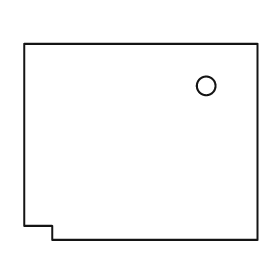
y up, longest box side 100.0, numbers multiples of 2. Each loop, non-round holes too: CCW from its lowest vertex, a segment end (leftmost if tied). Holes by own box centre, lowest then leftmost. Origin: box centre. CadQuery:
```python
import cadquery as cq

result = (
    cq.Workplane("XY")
    .moveTo(-38.0, -42.0)
    .lineTo(50.0, -42.0)
    .lineTo(50.0, 42.0)
    .lineTo(-50.0, 42.0)
    .lineTo(-50.0, -36.0)
    .lineTo(-38.0, -36.0)
    .close()
    .moveTo(28.0, 24.0)
    .circle(4.0)
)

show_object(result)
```